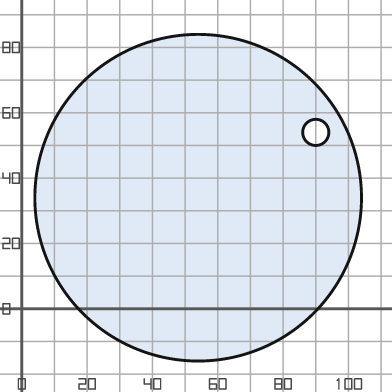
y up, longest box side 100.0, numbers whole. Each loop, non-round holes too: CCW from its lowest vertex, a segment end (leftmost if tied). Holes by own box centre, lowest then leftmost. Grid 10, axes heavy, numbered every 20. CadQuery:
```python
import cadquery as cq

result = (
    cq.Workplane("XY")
    .moveTo(54.0, 34.0)
    .circle(50.0)
    .moveTo(90.0, 54.0)
    .circle(4.0)
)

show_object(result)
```